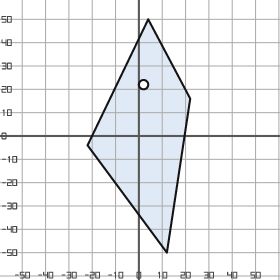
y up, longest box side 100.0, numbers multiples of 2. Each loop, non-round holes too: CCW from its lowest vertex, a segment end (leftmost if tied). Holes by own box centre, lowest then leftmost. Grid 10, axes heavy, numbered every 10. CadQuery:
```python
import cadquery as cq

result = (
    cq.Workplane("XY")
    .moveTo(12.0, -50.0)
    .lineTo(22.0, 16.0)
    .lineTo(4.0, 50.0)
    .lineTo(-22.0, -4.0)
    .close()
    .moveTo(2.0, 22.0)
    .circle(2.0)
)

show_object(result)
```